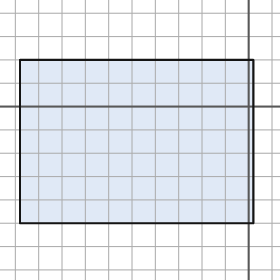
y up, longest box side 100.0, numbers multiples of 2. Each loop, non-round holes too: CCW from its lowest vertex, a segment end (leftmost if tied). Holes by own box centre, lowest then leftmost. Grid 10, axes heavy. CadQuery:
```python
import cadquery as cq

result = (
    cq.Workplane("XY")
    .moveTo(-98.0, -50.0)
    .lineTo(2.0, -50.0)
    .lineTo(2.0, 20.0)
    .lineTo(-98.0, 20.0)
    .close()
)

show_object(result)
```